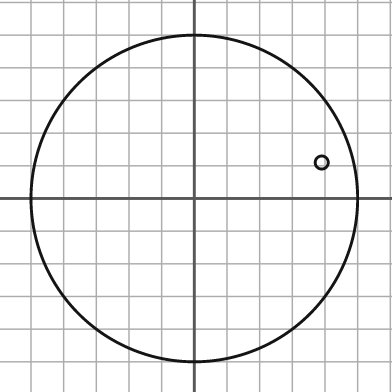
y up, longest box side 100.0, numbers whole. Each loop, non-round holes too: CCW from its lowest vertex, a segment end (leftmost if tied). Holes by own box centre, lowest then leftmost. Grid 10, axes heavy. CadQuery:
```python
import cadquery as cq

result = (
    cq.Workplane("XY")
    .moveTo(0.0, 0.0)
    .circle(50.0)
    .moveTo(39.0, 11.0)
    .circle(2.0)
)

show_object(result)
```